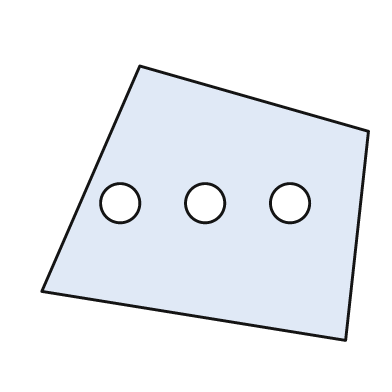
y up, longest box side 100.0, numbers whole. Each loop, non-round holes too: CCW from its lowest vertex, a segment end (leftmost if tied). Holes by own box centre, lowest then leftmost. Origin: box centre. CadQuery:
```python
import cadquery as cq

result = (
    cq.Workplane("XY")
    .moveTo(43.0, -42.0)
    .lineTo(50.0, 22.0)
    .lineTo(-20.0, 42.0)
    .lineTo(-50.0, -27.0)
    .close()
    .moveTo(-26.0, 0.0)
    .circle(6.0)
    .moveTo(0.0, 0.0)
    .circle(6.0)
    .moveTo(26.0, 0.0)
    .circle(6.0)
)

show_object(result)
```